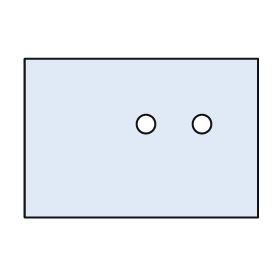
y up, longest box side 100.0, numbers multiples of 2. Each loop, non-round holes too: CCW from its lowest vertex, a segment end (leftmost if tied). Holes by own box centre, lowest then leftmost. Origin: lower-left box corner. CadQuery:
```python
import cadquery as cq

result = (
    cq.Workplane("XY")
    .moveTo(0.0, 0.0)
    .lineTo(100.0, 0.0)
    .lineTo(100.0, 68.0)
    .lineTo(0.0, 68.0)
    .close()
    .moveTo(52.0, 40.0)
    .circle(4.0)
    .moveTo(76.0, 40.0)
    .circle(4.0)
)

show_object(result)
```